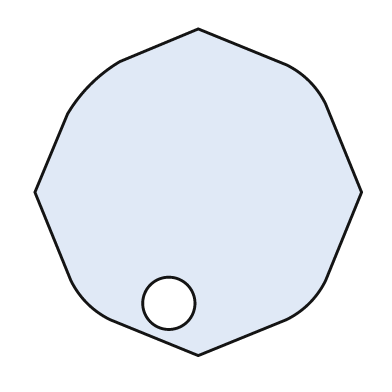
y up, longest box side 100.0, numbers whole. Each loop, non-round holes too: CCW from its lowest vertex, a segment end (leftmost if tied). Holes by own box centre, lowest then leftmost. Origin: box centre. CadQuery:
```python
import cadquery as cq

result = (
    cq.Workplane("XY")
    .moveTo(0.0, -50.0)
    .lineTo(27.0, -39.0)
    .threePointArc((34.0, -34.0), (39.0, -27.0))
    .lineTo(50.0, 0.0)
    .lineTo(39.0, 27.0)
    .threePointArc((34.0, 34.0), (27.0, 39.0))
    .lineTo(0.0, 50.0)
    .lineTo(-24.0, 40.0)
    .threePointArc((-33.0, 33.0), (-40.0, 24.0))
    .lineTo(-50.0, 0.0)
    .lineTo(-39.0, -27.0)
    .threePointArc((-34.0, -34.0), (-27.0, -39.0))
    .close()
    .moveTo(-9.0, -34.0)
    .circle(8.0)
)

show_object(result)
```